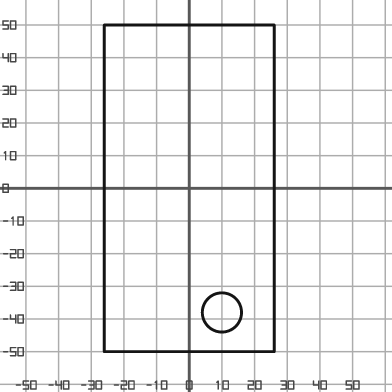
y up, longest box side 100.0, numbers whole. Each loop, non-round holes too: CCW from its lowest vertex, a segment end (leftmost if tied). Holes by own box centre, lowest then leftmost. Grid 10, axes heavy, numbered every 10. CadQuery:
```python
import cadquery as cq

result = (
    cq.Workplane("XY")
    .moveTo(-26.0, -50.0)
    .lineTo(26.0, -50.0)
    .lineTo(26.0, 50.0)
    .lineTo(-26.0, 50.0)
    .close()
    .moveTo(10.0, -38.0)
    .circle(6.0)
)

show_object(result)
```